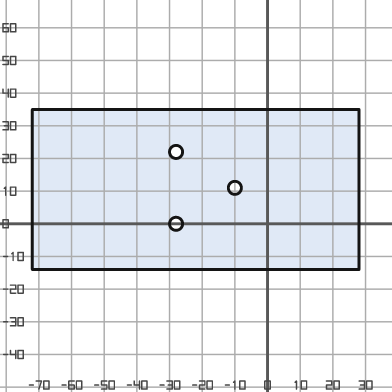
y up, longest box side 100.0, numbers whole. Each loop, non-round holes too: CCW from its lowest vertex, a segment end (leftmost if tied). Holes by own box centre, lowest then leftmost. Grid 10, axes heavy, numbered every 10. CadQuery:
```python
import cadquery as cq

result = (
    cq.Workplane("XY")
    .moveTo(-72.0, -14.0)
    .lineTo(28.0, -14.0)
    .lineTo(28.0, 35.0)
    .lineTo(-72.0, 35.0)
    .close()
    .moveTo(-28.0, 0.0)
    .circle(2.0)
    .moveTo(-10.0, 11.0)
    .circle(2.0)
    .moveTo(-28.0, 22.0)
    .circle(2.0)
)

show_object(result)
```